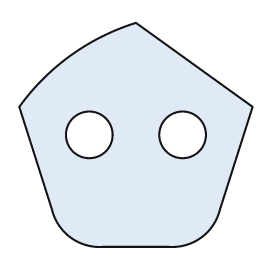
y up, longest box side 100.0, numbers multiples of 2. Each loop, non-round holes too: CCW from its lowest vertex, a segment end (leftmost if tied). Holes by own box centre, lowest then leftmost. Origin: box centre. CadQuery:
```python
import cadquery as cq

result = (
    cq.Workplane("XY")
    .moveTo(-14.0, -48.0)
    .lineTo(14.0, -48.0)
    .threePointArc((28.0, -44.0), (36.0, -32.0))
    .lineTo(50.0, 12.0)
    .lineTo(0.0, 48.0)
    .threePointArc((-28.0, 34.0), (-50.0, 12.0))
    .lineTo(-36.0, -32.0)
    .threePointArc((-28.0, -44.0), (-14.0, -48.0))
    .close()
    .moveTo(-20.0, 0.0)
    .circle(10.0)
    .moveTo(20.0, 0.0)
    .circle(10.0)
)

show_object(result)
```